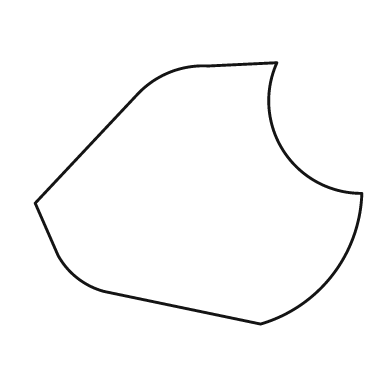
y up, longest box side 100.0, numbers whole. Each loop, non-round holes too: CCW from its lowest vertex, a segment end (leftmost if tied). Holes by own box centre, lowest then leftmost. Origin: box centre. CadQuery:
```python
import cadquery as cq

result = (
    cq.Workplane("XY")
    .moveTo(19.0, -40.0)
    .threePointArc((41.0, -25.0), (50.0, 0.0))
    .threePointArc((26.0, 13.0), (24.0, 40.0))
    .lineTo(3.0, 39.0)
    .threePointArc((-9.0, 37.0), (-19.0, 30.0))
    .lineTo(-50.0, -3.0)
    .lineTo(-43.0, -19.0)
    .threePointArc((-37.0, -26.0), (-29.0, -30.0))
    .close()
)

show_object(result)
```